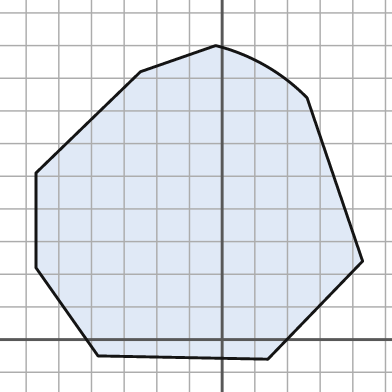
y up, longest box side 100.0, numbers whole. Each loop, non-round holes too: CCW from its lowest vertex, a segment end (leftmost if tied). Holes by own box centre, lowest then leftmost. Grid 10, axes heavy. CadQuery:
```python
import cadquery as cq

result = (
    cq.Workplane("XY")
    .moveTo(14.0, -6.0)
    .lineTo(43.0, 24.0)
    .lineTo(26.0, 74.0)
    .threePointArc((13.0, 84.0), (-2.0, 90.0))
    .lineTo(-25.0, 82.0)
    .lineTo(-57.0, 51.0)
    .lineTo(-57.0, 22.0)
    .lineTo(-38.0, -5.0)
    .close()
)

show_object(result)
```